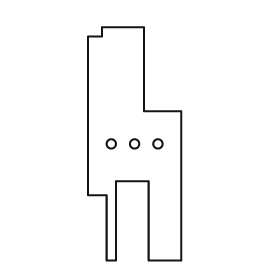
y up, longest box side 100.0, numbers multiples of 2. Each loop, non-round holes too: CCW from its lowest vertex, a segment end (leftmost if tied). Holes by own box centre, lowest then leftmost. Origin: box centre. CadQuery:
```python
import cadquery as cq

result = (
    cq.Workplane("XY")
    .moveTo(-12.0, -50.0)
    .lineTo(-8.0, -50.0)
    .lineTo(-8.0, -16.0)
    .lineTo(6.0, -16.0)
    .lineTo(6.0, -50.0)
    .lineTo(20.0, -50.0)
    .lineTo(20.0, 14.0)
    .lineTo(4.0, 14.0)
    .lineTo(4.0, 50.0)
    .lineTo(-14.0, 50.0)
    .lineTo(-14.0, 46.0)
    .lineTo(-20.0, 46.0)
    .lineTo(-20.0, -22.0)
    .lineTo(-12.0, -22.0)
    .close()
    .moveTo(-10.0, 0.0)
    .circle(2.0)
    .moveTo(0.0, 0.0)
    .circle(2.0)
    .moveTo(10.0, 0.0)
    .circle(2.0)
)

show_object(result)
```